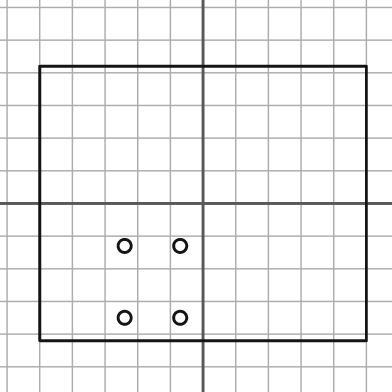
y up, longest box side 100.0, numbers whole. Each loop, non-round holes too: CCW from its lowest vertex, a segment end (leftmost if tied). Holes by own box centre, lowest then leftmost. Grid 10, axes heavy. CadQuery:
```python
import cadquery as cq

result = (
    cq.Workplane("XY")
    .moveTo(-50.0, -42.0)
    .lineTo(50.0, -42.0)
    .lineTo(50.0, 42.0)
    .lineTo(-50.0, 42.0)
    .close()
    .moveTo(-24.0, -35.0)
    .circle(2.0)
    .moveTo(-7.0, -35.0)
    .circle(2.0)
    .moveTo(-24.0, -13.0)
    .circle(2.0)
    .moveTo(-7.0, -13.0)
    .circle(2.0)
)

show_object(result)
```